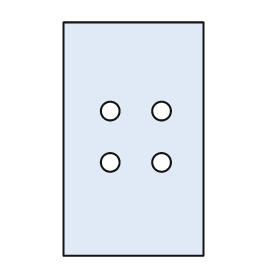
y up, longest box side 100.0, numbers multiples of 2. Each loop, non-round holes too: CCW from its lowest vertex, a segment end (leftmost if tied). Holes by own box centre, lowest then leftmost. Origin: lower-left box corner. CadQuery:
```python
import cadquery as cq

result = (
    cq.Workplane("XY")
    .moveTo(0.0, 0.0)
    .lineTo(60.0, 0.0)
    .lineTo(60.0, 100.0)
    .lineTo(0.0, 100.0)
    .close()
    .moveTo(20.0, 40.0)
    .circle(4.0)
    .moveTo(42.0, 40.0)
    .circle(4.0)
    .moveTo(20.0, 62.0)
    .circle(4.0)
    .moveTo(42.0, 62.0)
    .circle(4.0)
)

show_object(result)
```